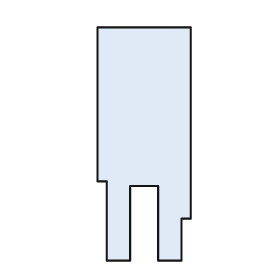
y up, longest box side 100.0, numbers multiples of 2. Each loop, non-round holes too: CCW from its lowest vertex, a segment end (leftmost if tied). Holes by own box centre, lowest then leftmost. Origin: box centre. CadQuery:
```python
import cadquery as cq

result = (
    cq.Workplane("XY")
    .moveTo(-16.0, -50.0)
    .lineTo(-6.0, -50.0)
    .lineTo(-6.0, -18.0)
    .lineTo(6.0, -18.0)
    .lineTo(6.0, -50.0)
    .lineTo(16.0, -50.0)
    .lineTo(16.0, -32.0)
    .lineTo(20.0, -32.0)
    .lineTo(20.0, 50.0)
    .lineTo(-20.0, 50.0)
    .lineTo(-20.0, -16.0)
    .lineTo(-16.0, -16.0)
    .close()
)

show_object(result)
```